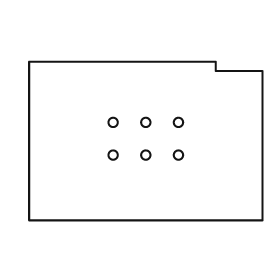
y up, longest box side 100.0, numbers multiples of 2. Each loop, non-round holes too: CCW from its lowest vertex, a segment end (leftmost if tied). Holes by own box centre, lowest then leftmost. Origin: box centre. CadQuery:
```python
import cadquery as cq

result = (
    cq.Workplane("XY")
    .moveTo(-50.0, -34.0)
    .lineTo(50.0, -34.0)
    .lineTo(50.0, 30.0)
    .lineTo(30.0, 30.0)
    .lineTo(30.0, 34.0)
    .lineTo(-50.0, 34.0)
    .close()
    .moveTo(-14.0, -6.0)
    .circle(2.0)
    .moveTo(0.0, -6.0)
    .circle(2.0)
    .moveTo(14.0, -6.0)
    .circle(2.0)
    .moveTo(-14.0, 8.0)
    .circle(2.0)
    .moveTo(0.0, 8.0)
    .circle(2.0)
    .moveTo(14.0, 8.0)
    .circle(2.0)
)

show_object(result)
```